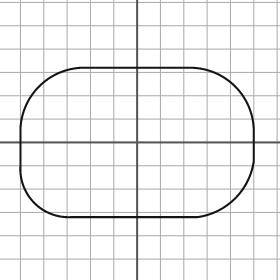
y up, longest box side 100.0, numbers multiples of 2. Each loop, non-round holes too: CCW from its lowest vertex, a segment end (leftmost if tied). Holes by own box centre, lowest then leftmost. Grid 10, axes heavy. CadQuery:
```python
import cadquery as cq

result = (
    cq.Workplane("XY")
    .moveTo(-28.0, -32.0)
    .lineTo(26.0, -32.0)
    .threePointArc((42.0, -24.0), (50.0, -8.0))
    .lineTo(50.0, 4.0)
    .threePointArc((42.0, 24.0), (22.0, 32.0))
    .lineTo(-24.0, 32.0)
    .threePointArc((-42.0, 24.0), (-50.0, 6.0))
    .lineTo(-50.0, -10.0)
    .threePointArc((-44.0, -26.0), (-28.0, -32.0))
    .close()
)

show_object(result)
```